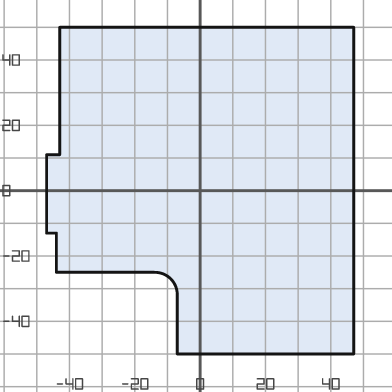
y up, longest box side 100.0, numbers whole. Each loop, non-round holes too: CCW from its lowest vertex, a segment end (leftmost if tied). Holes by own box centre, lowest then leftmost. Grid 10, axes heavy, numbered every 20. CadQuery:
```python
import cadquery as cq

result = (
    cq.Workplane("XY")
    .moveTo(-7.0, -50.0)
    .lineTo(47.0, -50.0)
    .lineTo(47.0, 50.0)
    .lineTo(-43.0, 50.0)
    .lineTo(-43.0, 11.0)
    .lineTo(-47.0, 11.0)
    .lineTo(-47.0, -13.0)
    .lineTo(-44.0, -13.0)
    .lineTo(-44.0, -25.0)
    .lineTo(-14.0, -25.0)
    .threePointArc((-9.0, -27.0), (-7.0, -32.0))
    .close()
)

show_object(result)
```